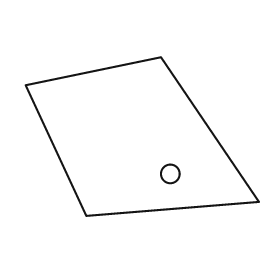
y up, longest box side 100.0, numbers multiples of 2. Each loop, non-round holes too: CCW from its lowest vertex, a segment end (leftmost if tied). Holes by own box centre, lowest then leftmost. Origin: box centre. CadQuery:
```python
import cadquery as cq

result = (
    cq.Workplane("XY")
    .moveTo(-24.0, -34.0)
    .lineTo(50.0, -28.0)
    .lineTo(8.0, 34.0)
    .lineTo(-50.0, 22.0)
    .close()
    .moveTo(12.0, -16.0)
    .circle(4.0)
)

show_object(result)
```